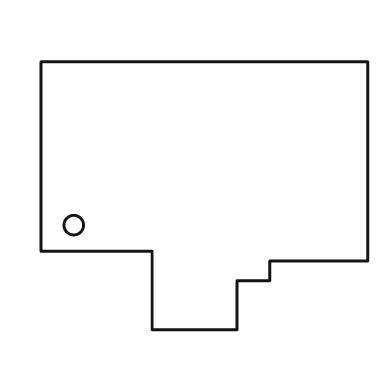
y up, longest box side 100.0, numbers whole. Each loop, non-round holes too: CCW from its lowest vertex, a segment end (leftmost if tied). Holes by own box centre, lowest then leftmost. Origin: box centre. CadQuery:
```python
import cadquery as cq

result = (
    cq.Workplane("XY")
    .moveTo(-16.0, -41.0)
    .lineTo(10.0, -41.0)
    .lineTo(10.0, -26.0)
    .lineTo(20.0, -26.0)
    .lineTo(20.0, -20.0)
    .lineTo(50.0, -20.0)
    .lineTo(50.0, 41.0)
    .lineTo(-50.0, 41.0)
    .lineTo(-50.0, -17.0)
    .lineTo(-16.0, -17.0)
    .close()
    .moveTo(-40.0, -9.0)
    .circle(3.0)
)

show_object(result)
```